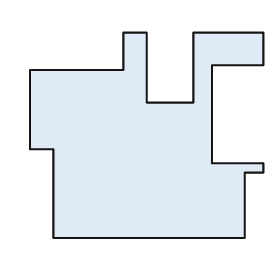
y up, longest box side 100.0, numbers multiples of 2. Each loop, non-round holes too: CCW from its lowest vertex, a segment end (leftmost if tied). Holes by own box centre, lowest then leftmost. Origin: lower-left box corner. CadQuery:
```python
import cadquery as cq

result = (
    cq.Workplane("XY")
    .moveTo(10.0, 0.0)
    .lineTo(92.0, 0.0)
    .lineTo(92.0, 28.0)
    .lineTo(100.0, 28.0)
    .lineTo(100.0, 32.0)
    .lineTo(78.0, 32.0)
    .lineTo(78.0, 74.0)
    .lineTo(100.0, 74.0)
    .lineTo(100.0, 88.0)
    .lineTo(70.0, 88.0)
    .lineTo(70.0, 58.0)
    .lineTo(50.0, 58.0)
    .lineTo(50.0, 88.0)
    .lineTo(40.0, 88.0)
    .lineTo(40.0, 72.0)
    .lineTo(0.0, 72.0)
    .lineTo(0.0, 38.0)
    .lineTo(10.0, 38.0)
    .close()
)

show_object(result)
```